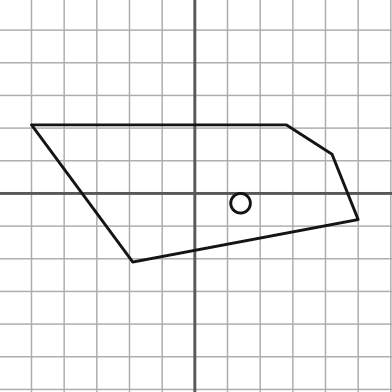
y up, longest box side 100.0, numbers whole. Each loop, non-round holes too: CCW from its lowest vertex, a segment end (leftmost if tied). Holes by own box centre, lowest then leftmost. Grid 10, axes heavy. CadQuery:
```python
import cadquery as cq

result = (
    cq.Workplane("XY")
    .moveTo(-19.0, -21.0)
    .lineTo(50.0, -8.0)
    .lineTo(42.0, 12.0)
    .lineTo(28.0, 21.0)
    .lineTo(-50.0, 21.0)
    .close()
    .moveTo(14.0, -3.0)
    .circle(3.0)
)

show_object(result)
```